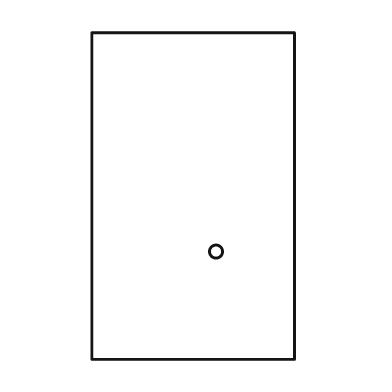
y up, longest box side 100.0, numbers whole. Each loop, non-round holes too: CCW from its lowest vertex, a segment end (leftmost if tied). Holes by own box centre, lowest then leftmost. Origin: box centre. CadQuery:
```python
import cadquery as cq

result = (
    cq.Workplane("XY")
    .moveTo(-31.0, -50.0)
    .lineTo(31.0, -50.0)
    .lineTo(31.0, 50.0)
    .lineTo(-31.0, 50.0)
    .close()
    .moveTo(7.0, -17.0)
    .circle(2.0)
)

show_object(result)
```